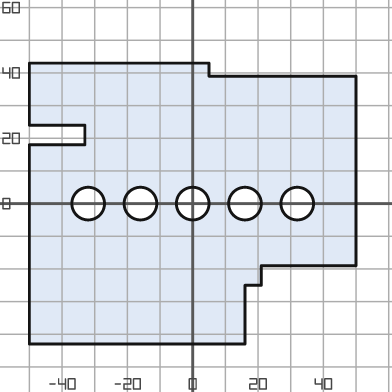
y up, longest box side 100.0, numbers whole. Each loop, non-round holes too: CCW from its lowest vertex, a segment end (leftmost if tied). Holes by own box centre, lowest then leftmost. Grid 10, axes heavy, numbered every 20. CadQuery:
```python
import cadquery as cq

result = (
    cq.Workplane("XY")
    .moveTo(-50.0, -43.0)
    .lineTo(16.0, -43.0)
    .lineTo(16.0, -25.0)
    .lineTo(21.0, -25.0)
    .lineTo(21.0, -19.0)
    .lineTo(50.0, -19.0)
    .lineTo(50.0, 39.0)
    .lineTo(5.0, 39.0)
    .lineTo(5.0, 43.0)
    .lineTo(-50.0, 43.0)
    .lineTo(-50.0, 24.0)
    .lineTo(-33.0, 24.0)
    .lineTo(-33.0, 18.0)
    .lineTo(-50.0, 18.0)
    .close()
    .moveTo(-32.0, 0.0)
    .circle(5.0)
    .moveTo(-16.0, 0.0)
    .circle(5.0)
    .moveTo(0.0, 0.0)
    .circle(5.0)
    .moveTo(16.0, 0.0)
    .circle(5.0)
    .moveTo(32.0, 0.0)
    .circle(5.0)
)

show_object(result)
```